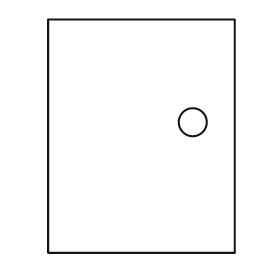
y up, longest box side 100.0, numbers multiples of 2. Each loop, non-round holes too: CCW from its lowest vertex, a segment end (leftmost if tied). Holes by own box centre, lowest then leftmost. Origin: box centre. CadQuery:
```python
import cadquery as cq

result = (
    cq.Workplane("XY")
    .moveTo(-40.0, -50.0)
    .lineTo(40.0, -50.0)
    .lineTo(40.0, 50.0)
    .lineTo(-40.0, 50.0)
    .close()
    .moveTo(22.0, 6.0)
    .circle(6.0)
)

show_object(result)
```